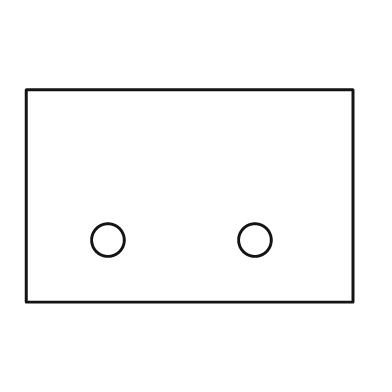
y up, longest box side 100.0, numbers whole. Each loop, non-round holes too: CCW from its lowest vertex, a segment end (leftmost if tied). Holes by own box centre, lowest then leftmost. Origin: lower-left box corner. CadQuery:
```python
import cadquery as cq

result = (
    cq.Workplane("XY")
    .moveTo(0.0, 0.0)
    .lineTo(100.0, 0.0)
    .lineTo(100.0, 65.0)
    .lineTo(0.0, 65.0)
    .close()
    .moveTo(25.0, 19.0)
    .circle(5.0)
    .moveTo(70.0, 19.0)
    .circle(5.0)
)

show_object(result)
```